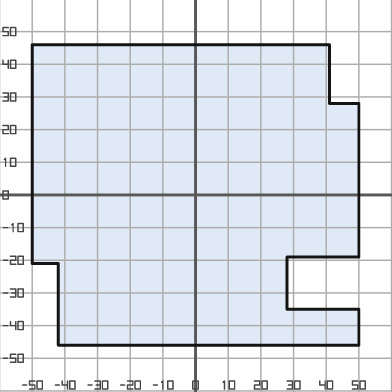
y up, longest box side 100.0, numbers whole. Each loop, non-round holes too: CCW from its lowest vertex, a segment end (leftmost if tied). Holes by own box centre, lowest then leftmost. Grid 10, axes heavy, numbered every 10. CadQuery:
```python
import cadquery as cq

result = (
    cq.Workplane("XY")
    .moveTo(-42.0, -46.0)
    .lineTo(50.0, -46.0)
    .lineTo(50.0, -35.0)
    .lineTo(28.0, -35.0)
    .lineTo(28.0, -19.0)
    .lineTo(50.0, -19.0)
    .lineTo(50.0, 28.0)
    .lineTo(41.0, 28.0)
    .lineTo(41.0, 46.0)
    .lineTo(-50.0, 46.0)
    .lineTo(-50.0, -21.0)
    .lineTo(-42.0, -21.0)
    .close()
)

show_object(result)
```